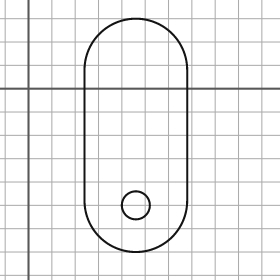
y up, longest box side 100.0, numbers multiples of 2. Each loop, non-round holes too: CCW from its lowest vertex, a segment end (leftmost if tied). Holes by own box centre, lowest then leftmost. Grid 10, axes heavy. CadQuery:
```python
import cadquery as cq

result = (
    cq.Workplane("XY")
    .moveTo(24.0, -48.0)
    .threePointArc((46.0, -70.0), (68.0, -48.0))
    .lineTo(68.0, 8.0)
    .threePointArc((46.0, 30.0), (24.0, 8.0))
    .close()
    .moveTo(46.0, -50.0)
    .circle(6.0)
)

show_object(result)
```